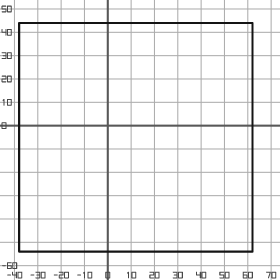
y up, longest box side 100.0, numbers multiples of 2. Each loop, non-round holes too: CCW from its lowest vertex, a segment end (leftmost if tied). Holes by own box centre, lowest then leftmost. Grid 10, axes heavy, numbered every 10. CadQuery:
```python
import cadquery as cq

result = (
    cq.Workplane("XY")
    .moveTo(-38.0, -54.0)
    .lineTo(62.0, -54.0)
    .lineTo(62.0, 44.0)
    .lineTo(-38.0, 44.0)
    .close()
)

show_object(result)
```